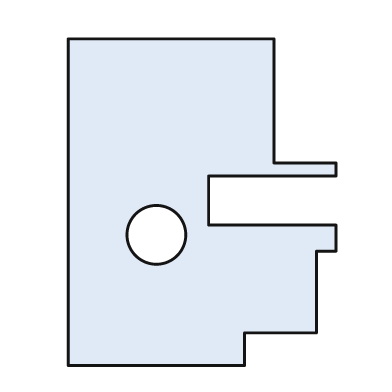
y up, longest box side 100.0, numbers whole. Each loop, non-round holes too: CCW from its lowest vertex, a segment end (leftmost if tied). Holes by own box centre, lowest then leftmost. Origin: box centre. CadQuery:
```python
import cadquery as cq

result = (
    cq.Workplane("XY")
    .moveTo(-41.0, -50.0)
    .lineTo(13.0, -50.0)
    .lineTo(13.0, -40.0)
    .lineTo(35.0, -40.0)
    .lineTo(35.0, -15.0)
    .lineTo(41.0, -15.0)
    .lineTo(41.0, -7.0)
    .lineTo(2.0, -7.0)
    .lineTo(2.0, 8.0)
    .lineTo(41.0, 8.0)
    .lineTo(41.0, 12.0)
    .lineTo(22.0, 12.0)
    .lineTo(22.0, 50.0)
    .lineTo(-41.0, 50.0)
    .close()
    .moveTo(-14.0, -10.0)
    .circle(9.0)
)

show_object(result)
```